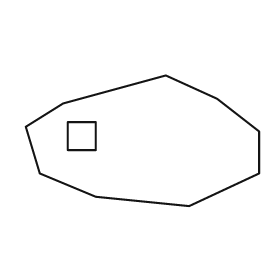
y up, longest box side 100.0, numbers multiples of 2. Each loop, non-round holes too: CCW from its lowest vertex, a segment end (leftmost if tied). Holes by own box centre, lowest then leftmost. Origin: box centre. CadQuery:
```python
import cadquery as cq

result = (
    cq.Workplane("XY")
    .moveTo(20.0, -28.0)
    .lineTo(50.0, -14.0)
    .lineTo(50.0, 4.0)
    .lineTo(32.0, 18.0)
    .lineTo(10.0, 28.0)
    .lineTo(-34.0, 16.0)
    .lineTo(-50.0, 6.0)
    .lineTo(-44.0, -14.0)
    .lineTo(-20.0, -24.0)
    .close()
    .moveTo(-32.0, -4.0)
    .lineTo(-20.0, -4.0)
    .lineTo(-20.0, 8.0)
    .lineTo(-32.0, 8.0)
    .close()
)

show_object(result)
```